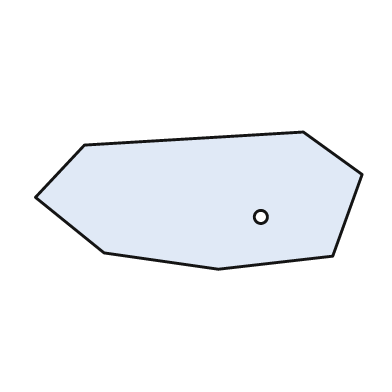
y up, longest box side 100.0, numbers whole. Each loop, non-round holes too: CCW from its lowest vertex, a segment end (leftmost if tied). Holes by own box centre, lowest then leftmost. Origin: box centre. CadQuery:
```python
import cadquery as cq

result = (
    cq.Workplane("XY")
    .moveTo(6.0, -21.0)
    .lineTo(41.0, -17.0)
    .lineTo(50.0, 8.0)
    .lineTo(32.0, 21.0)
    .lineTo(-35.0, 17.0)
    .lineTo(-50.0, 1.0)
    .lineTo(-29.0, -16.0)
    .close()
    .moveTo(19.0, -5.0)
    .circle(2.0)
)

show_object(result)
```